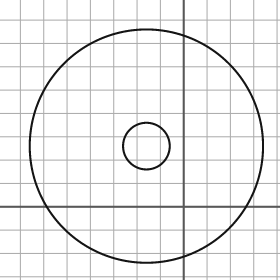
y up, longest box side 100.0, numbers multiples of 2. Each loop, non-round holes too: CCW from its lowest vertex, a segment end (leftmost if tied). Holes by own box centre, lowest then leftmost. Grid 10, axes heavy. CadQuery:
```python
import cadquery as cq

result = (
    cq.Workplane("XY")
    .moveTo(-16.0, 26.0)
    .circle(50.0)
    .moveTo(-16.0, 26.0)
    .circle(10.0)
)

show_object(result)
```